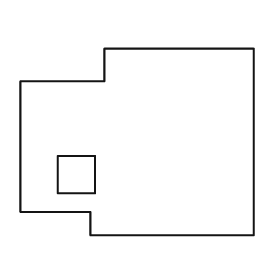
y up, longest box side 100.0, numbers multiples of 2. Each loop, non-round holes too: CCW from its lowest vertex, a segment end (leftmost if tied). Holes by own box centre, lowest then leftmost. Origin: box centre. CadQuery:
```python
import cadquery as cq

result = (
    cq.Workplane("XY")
    .moveTo(-20.0, -40.0)
    .lineTo(50.0, -40.0)
    .lineTo(50.0, 40.0)
    .lineTo(-14.0, 40.0)
    .lineTo(-14.0, 26.0)
    .lineTo(-50.0, 26.0)
    .lineTo(-50.0, -30.0)
    .lineTo(-20.0, -30.0)
    .close()
    .moveTo(-34.0, -22.0)
    .lineTo(-18.0, -22.0)
    .lineTo(-18.0, -6.0)
    .lineTo(-34.0, -6.0)
    .close()
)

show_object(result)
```